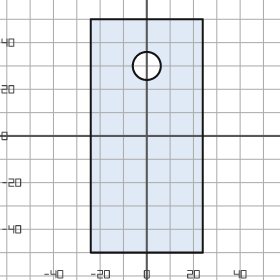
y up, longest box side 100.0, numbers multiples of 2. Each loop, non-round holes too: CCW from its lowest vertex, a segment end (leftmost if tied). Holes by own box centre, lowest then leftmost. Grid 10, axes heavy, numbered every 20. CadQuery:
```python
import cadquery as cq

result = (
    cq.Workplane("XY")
    .moveTo(-24.0, -50.0)
    .lineTo(24.0, -50.0)
    .lineTo(24.0, 50.0)
    .lineTo(-24.0, 50.0)
    .close()
    .moveTo(0.0, 30.0)
    .circle(6.0)
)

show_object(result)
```